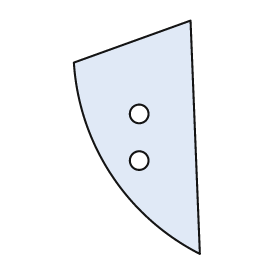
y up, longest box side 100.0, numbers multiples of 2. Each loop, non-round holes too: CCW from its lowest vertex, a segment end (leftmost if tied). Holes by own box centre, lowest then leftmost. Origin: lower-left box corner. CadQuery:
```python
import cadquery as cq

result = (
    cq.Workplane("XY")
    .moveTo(54.0, 0.0)
    .lineTo(50.0, 100.0)
    .lineTo(0.0, 82.0)
    .threePointArc((16.0, 34.0), (54.0, 0.0))
    .close()
    .moveTo(28.0, 40.0)
    .circle(4.0)
    .moveTo(28.0, 60.0)
    .circle(4.0)
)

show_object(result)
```